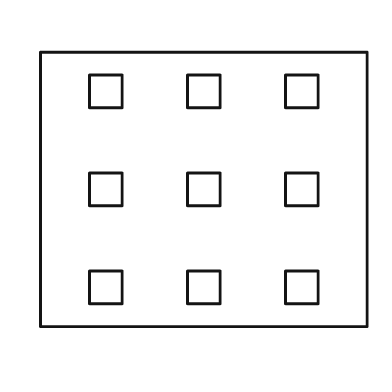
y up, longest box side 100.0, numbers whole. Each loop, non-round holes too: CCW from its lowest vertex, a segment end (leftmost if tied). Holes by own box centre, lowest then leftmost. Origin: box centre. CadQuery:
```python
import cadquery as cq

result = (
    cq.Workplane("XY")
    .moveTo(-50.0, -42.0)
    .lineTo(50.0, -42.0)
    .lineTo(50.0, 42.0)
    .lineTo(-50.0, 42.0)
    .close()
    .moveTo(-35.0, -35.0)
    .lineTo(-25.0, -35.0)
    .lineTo(-25.0, -25.0)
    .lineTo(-35.0, -25.0)
    .close()
    .moveTo(-5.0, -35.0)
    .lineTo(5.0, -35.0)
    .lineTo(5.0, -25.0)
    .lineTo(-5.0, -25.0)
    .close()
    .moveTo(25.0, -35.0)
    .lineTo(35.0, -35.0)
    .lineTo(35.0, -25.0)
    .lineTo(25.0, -25.0)
    .close()
    .moveTo(-35.0, -5.0)
    .lineTo(-25.0, -5.0)
    .lineTo(-25.0, 5.0)
    .lineTo(-35.0, 5.0)
    .close()
    .moveTo(-5.0, -5.0)
    .lineTo(5.0, -5.0)
    .lineTo(5.0, 5.0)
    .lineTo(-5.0, 5.0)
    .close()
    .moveTo(25.0, -5.0)
    .lineTo(35.0, -5.0)
    .lineTo(35.0, 5.0)
    .lineTo(25.0, 5.0)
    .close()
    .moveTo(-35.0, 25.0)
    .lineTo(-25.0, 25.0)
    .lineTo(-25.0, 35.0)
    .lineTo(-35.0, 35.0)
    .close()
    .moveTo(-5.0, 25.0)
    .lineTo(5.0, 25.0)
    .lineTo(5.0, 35.0)
    .lineTo(-5.0, 35.0)
    .close()
    .moveTo(25.0, 25.0)
    .lineTo(35.0, 25.0)
    .lineTo(35.0, 35.0)
    .lineTo(25.0, 35.0)
    .close()
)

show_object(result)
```